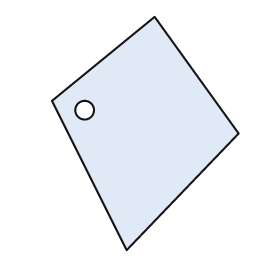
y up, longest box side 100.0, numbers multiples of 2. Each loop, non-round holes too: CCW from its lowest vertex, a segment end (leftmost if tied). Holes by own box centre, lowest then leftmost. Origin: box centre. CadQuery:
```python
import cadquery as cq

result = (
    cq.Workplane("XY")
    .moveTo(-8.0, -50.0)
    .lineTo(40.0, 0.0)
    .lineTo(4.0, 50.0)
    .lineTo(-40.0, 14.0)
    .close()
    .moveTo(-26.0, 10.0)
    .circle(4.0)
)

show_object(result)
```